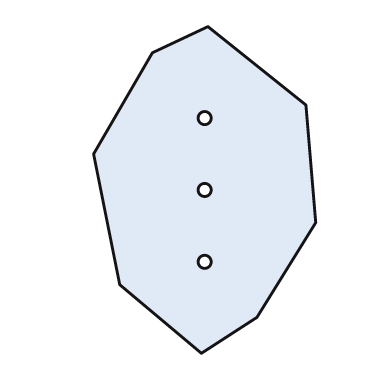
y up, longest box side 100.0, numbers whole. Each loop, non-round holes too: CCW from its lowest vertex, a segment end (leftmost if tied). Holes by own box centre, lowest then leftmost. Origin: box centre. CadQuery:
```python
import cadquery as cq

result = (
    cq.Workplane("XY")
    .moveTo(-1.0, -50.0)
    .lineTo(16.0, -39.0)
    .lineTo(34.0, -10.0)
    .lineTo(31.0, 26.0)
    .lineTo(1.0, 50.0)
    .lineTo(-16.0, 42.0)
    .lineTo(-34.0, 11.0)
    .lineTo(-26.0, -29.0)
    .close()
    .moveTo(0.0, -22.0)
    .circle(2.0)
    .moveTo(0.0, 0.0)
    .circle(2.0)
    .moveTo(0.0, 22.0)
    .circle(2.0)
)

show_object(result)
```